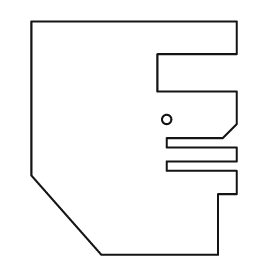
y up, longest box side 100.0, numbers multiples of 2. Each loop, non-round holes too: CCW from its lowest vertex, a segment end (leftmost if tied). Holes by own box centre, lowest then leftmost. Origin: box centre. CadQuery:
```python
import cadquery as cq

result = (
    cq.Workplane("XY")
    .moveTo(-14.0, -50.0)
    .lineTo(36.0, -50.0)
    .lineTo(36.0, -24.0)
    .lineTo(44.0, -24.0)
    .lineTo(44.0, -14.0)
    .lineTo(14.0, -14.0)
    .lineTo(14.0, -10.0)
    .lineTo(44.0, -10.0)
    .lineTo(44.0, -4.0)
    .lineTo(14.0, -4.0)
    .lineTo(14.0, 0.0)
    .lineTo(38.0, 0.0)
    .lineTo(44.0, 6.0)
    .lineTo(44.0, 20.0)
    .lineTo(10.0, 20.0)
    .lineTo(10.0, 36.0)
    .lineTo(44.0, 36.0)
    .lineTo(44.0, 50.0)
    .lineTo(-44.0, 50.0)
    .lineTo(-44.0, -16.0)
    .close()
    .moveTo(14.0, 8.0)
    .circle(2.0)
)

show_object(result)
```